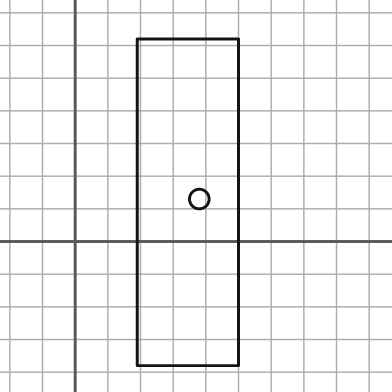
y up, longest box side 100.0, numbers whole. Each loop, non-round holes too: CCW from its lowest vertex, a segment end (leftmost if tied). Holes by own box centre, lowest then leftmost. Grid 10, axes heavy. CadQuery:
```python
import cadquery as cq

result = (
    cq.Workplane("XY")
    .moveTo(19.0, -38.0)
    .lineTo(50.0, -38.0)
    .lineTo(50.0, 62.0)
    .lineTo(19.0, 62.0)
    .close()
    .moveTo(38.0, 13.0)
    .circle(3.0)
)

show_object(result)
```